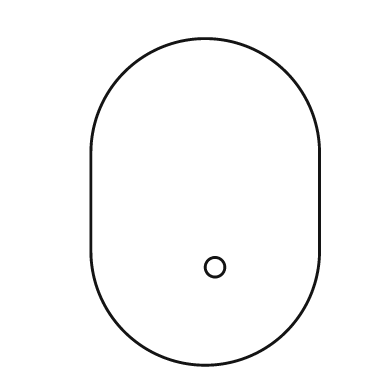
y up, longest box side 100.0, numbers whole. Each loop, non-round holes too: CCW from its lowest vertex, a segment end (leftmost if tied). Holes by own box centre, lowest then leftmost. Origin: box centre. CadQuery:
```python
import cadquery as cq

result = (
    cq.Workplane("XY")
    .moveTo(-35.0, -15.0)
    .threePointArc((0.0, -50.0), (35.0, -15.0))
    .lineTo(35.0, 15.0)
    .threePointArc((0.0, 50.0), (-35.0, 15.0))
    .close()
    .moveTo(3.0, -20.0)
    .circle(3.0)
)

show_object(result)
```